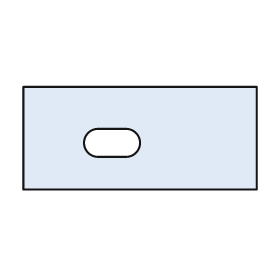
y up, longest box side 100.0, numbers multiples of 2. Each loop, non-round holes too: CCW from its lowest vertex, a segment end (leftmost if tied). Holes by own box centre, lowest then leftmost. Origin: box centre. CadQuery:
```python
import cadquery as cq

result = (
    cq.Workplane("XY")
    .moveTo(-50.0, -22.0)
    .lineTo(50.0, -22.0)
    .lineTo(50.0, 22.0)
    .lineTo(-50.0, 22.0)
    .close()
    .moveTo(-18.0, -8.0)
    .lineTo(-6.0, -8.0)
    .threePointArc((0.0, -2.0), (-6.0, 4.0))
    .lineTo(-18.0, 4.0)
    .threePointArc((-24.0, -2.0), (-18.0, -8.0))
    .close()
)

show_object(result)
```